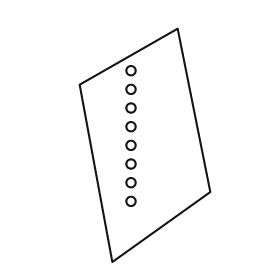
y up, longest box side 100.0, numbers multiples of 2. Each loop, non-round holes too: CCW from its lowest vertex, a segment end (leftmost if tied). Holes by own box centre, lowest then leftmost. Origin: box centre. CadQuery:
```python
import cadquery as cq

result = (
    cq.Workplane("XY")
    .moveTo(-14.0, -50.0)
    .lineTo(28.0, -20.0)
    .lineTo(14.0, 50.0)
    .lineTo(-28.0, 26.0)
    .close()
    .moveTo(-6.0, -24.0)
    .circle(2.0)
    .moveTo(-6.0, -16.0)
    .circle(2.0)
    .moveTo(-6.0, -8.0)
    .circle(2.0)
    .moveTo(-6.0, 0.0)
    .circle(2.0)
    .moveTo(-6.0, 8.0)
    .circle(2.0)
    .moveTo(-6.0, 16.0)
    .circle(2.0)
    .moveTo(-6.0, 24.0)
    .circle(2.0)
    .moveTo(-6.0, 32.0)
    .circle(2.0)
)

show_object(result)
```